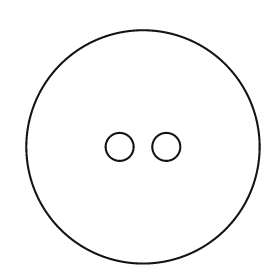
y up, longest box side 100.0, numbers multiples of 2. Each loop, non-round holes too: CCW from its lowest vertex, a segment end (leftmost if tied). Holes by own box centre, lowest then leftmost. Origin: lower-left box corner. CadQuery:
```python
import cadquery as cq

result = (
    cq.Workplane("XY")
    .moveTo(50.0, 50.0)
    .circle(50.0)
    .moveTo(40.0, 50.0)
    .circle(6.0)
    .moveTo(60.0, 50.0)
    .circle(6.0)
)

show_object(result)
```